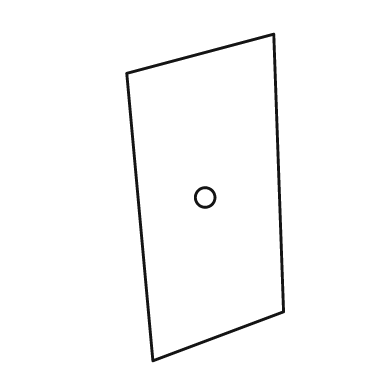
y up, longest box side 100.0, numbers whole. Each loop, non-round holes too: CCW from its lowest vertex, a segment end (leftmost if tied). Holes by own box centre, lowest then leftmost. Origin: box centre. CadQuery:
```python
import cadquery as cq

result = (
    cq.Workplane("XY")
    .moveTo(-16.0, -50.0)
    .lineTo(24.0, -35.0)
    .lineTo(21.0, 50.0)
    .lineTo(-24.0, 38.0)
    .close()
    .moveTo(0.0, 0.0)
    .circle(3.0)
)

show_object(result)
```